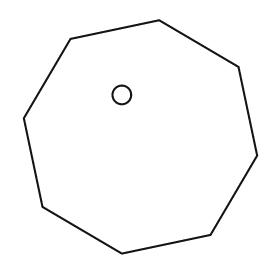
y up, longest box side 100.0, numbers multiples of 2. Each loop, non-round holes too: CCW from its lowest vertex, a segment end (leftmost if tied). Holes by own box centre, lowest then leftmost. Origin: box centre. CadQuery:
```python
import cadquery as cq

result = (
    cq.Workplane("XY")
    .moveTo(-8.0, -50.0)
    .lineTo(30.0, -42.0)
    .lineTo(50.0, -8.0)
    .lineTo(42.0, 30.0)
    .lineTo(8.0, 50.0)
    .lineTo(-30.0, 42.0)
    .lineTo(-50.0, 8.0)
    .lineTo(-42.0, -30.0)
    .close()
    .moveTo(-8.0, 18.0)
    .circle(4.0)
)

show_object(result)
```